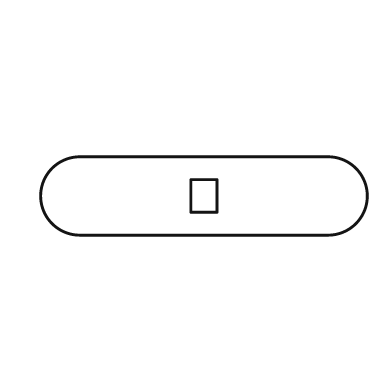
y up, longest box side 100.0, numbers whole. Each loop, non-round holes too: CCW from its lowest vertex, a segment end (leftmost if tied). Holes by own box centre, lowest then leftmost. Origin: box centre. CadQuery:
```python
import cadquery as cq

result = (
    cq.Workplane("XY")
    .moveTo(-38.0, -12.0)
    .lineTo(38.0, -12.0)
    .threePointArc((50.0, 0.0), (38.0, 12.0))
    .lineTo(-38.0, 12.0)
    .threePointArc((-50.0, 0.0), (-38.0, -12.0))
    .close()
    .moveTo(-4.0, -5.0)
    .lineTo(4.0, -5.0)
    .lineTo(4.0, 5.0)
    .lineTo(-4.0, 5.0)
    .close()
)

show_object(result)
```